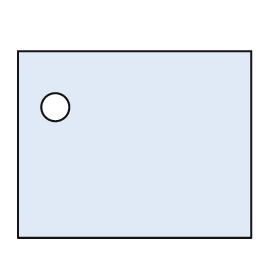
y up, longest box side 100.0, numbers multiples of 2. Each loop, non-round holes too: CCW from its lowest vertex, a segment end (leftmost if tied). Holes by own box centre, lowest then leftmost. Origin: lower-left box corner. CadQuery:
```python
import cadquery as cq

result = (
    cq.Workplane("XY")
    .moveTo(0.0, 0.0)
    .lineTo(100.0, 0.0)
    .lineTo(100.0, 80.0)
    .lineTo(0.0, 80.0)
    .close()
    .moveTo(16.0, 56.0)
    .circle(6.0)
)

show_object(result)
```